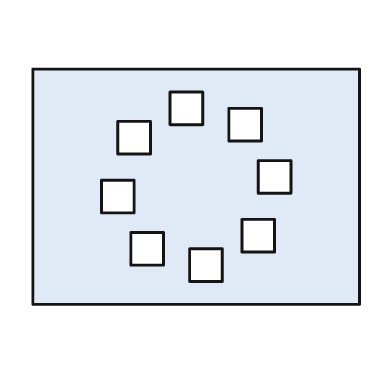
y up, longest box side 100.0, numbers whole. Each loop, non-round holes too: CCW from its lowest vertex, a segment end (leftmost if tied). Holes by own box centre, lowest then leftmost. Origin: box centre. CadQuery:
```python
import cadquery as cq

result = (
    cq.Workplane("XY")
    .moveTo(-50.0, -36.0)
    .lineTo(50.0, -36.0)
    .lineTo(50.0, 36.0)
    .lineTo(-50.0, 36.0)
    .close()
    .moveTo(-2.0, -29.0)
    .lineTo(8.0, -29.0)
    .lineTo(8.0, -19.0)
    .lineTo(-2.0, -19.0)
    .close()
    .moveTo(-20.0, -24.0)
    .lineTo(-10.0, -24.0)
    .lineTo(-10.0, -14.0)
    .lineTo(-20.0, -14.0)
    .close()
    .moveTo(14.0, -20.0)
    .lineTo(24.0, -20.0)
    .lineTo(24.0, -10.0)
    .lineTo(14.0, -10.0)
    .close()
    .moveTo(-29.0, -8.0)
    .lineTo(-19.0, -8.0)
    .lineTo(-19.0, 2.0)
    .lineTo(-29.0, 2.0)
    .close()
    .moveTo(19.0, -2.0)
    .lineTo(29.0, -2.0)
    .lineTo(29.0, 8.0)
    .lineTo(19.0, 8.0)
    .close()
    .moveTo(-24.0, 10.0)
    .lineTo(-14.0, 10.0)
    .lineTo(-14.0, 20.0)
    .lineTo(-24.0, 20.0)
    .close()
    .moveTo(10.0, 14.0)
    .lineTo(20.0, 14.0)
    .lineTo(20.0, 24.0)
    .lineTo(10.0, 24.0)
    .close()
    .moveTo(-8.0, 19.0)
    .lineTo(2.0, 19.0)
    .lineTo(2.0, 29.0)
    .lineTo(-8.0, 29.0)
    .close()
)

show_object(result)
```